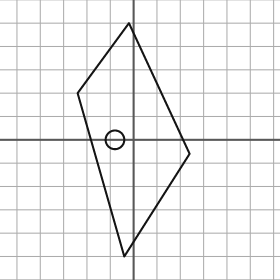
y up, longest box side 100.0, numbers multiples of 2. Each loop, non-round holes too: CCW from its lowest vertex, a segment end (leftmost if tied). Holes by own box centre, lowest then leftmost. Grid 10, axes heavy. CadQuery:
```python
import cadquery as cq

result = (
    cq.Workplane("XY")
    .moveTo(-4.0, -50.0)
    .lineTo(24.0, -6.0)
    .lineTo(-2.0, 50.0)
    .lineTo(-24.0, 20.0)
    .close()
    .moveTo(-8.0, 0.0)
    .circle(4.0)
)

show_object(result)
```